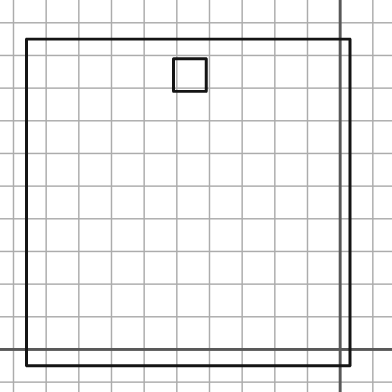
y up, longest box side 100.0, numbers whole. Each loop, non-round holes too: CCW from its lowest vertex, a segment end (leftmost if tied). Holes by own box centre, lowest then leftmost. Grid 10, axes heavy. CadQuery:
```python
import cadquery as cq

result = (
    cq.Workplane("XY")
    .moveTo(-96.0, -5.0)
    .lineTo(3.0, -5.0)
    .lineTo(3.0, 95.0)
    .lineTo(-96.0, 95.0)
    .close()
    .moveTo(-51.0, 79.0)
    .lineTo(-41.0, 79.0)
    .lineTo(-41.0, 89.0)
    .lineTo(-51.0, 89.0)
    .close()
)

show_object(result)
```